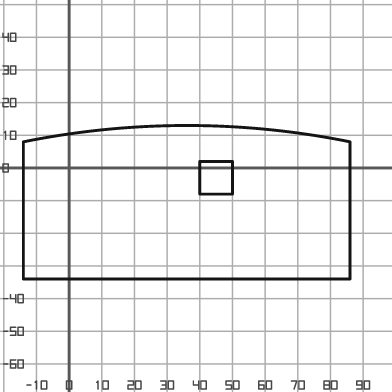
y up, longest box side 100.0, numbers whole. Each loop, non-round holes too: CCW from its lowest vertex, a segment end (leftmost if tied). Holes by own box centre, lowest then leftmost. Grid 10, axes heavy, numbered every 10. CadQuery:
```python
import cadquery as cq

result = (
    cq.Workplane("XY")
    .moveTo(-14.0, -34.0)
    .lineTo(86.0, -34.0)
    .lineTo(86.0, 8.0)
    .threePointArc((36.0, 13.0), (-14.0, 8.0))
    .close()
    .moveTo(40.0, -8.0)
    .lineTo(50.0, -8.0)
    .lineTo(50.0, 2.0)
    .lineTo(40.0, 2.0)
    .close()
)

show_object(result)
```